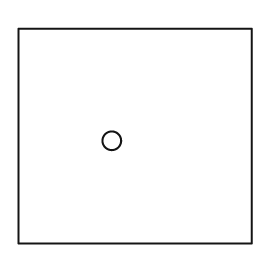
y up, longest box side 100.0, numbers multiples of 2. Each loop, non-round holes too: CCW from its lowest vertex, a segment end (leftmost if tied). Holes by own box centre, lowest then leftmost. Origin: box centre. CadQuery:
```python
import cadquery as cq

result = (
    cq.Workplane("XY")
    .moveTo(-50.0, -46.0)
    .lineTo(50.0, -46.0)
    .lineTo(50.0, 46.0)
    .lineTo(-50.0, 46.0)
    .close()
    .moveTo(-10.0, -2.0)
    .circle(4.0)
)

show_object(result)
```